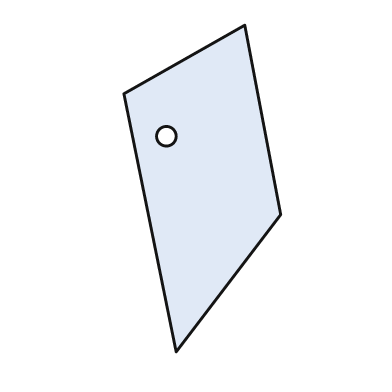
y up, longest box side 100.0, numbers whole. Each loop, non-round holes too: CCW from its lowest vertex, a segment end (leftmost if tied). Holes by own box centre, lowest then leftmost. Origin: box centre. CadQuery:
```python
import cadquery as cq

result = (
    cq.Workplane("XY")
    .moveTo(-8.0, -50.0)
    .lineTo(24.0, -8.0)
    .lineTo(13.0, 50.0)
    .lineTo(-24.0, 29.0)
    .close()
    .moveTo(-11.0, 16.0)
    .circle(3.0)
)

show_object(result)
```